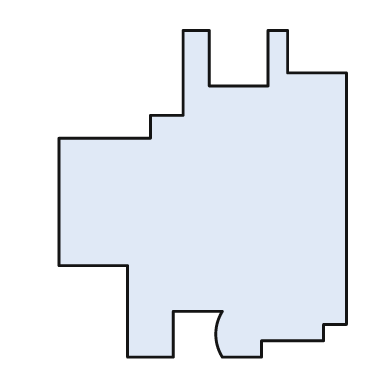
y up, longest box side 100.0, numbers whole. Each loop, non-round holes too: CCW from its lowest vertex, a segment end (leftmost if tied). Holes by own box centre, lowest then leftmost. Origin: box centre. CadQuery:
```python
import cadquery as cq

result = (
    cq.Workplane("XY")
    .moveTo(-23.0, -50.0)
    .lineTo(-9.0, -50.0)
    .lineTo(-9.0, -36.0)
    .lineTo(6.0, -36.0)
    .threePointArc((4.0, -43.0), (6.0, -50.0))
    .lineTo(18.0, -50.0)
    .lineTo(18.0, -45.0)
    .lineTo(37.0, -45.0)
    .lineTo(37.0, -40.0)
    .lineTo(44.0, -40.0)
    .lineTo(44.0, 37.0)
    .lineTo(26.0, 37.0)
    .lineTo(26.0, 50.0)
    .lineTo(20.0, 50.0)
    .lineTo(20.0, 33.0)
    .lineTo(2.0, 33.0)
    .lineTo(2.0, 50.0)
    .lineTo(-6.0, 50.0)
    .lineTo(-6.0, 24.0)
    .lineTo(-16.0, 24.0)
    .lineTo(-16.0, 17.0)
    .lineTo(-44.0, 17.0)
    .lineTo(-44.0, -22.0)
    .lineTo(-23.0, -22.0)
    .close()
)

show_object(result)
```